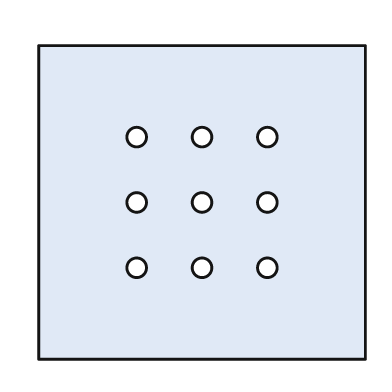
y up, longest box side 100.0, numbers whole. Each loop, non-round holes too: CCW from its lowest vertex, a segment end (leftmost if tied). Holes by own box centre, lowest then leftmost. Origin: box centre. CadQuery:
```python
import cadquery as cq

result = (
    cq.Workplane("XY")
    .moveTo(-50.0, -48.0)
    .lineTo(50.0, -48.0)
    .lineTo(50.0, 48.0)
    .lineTo(-50.0, 48.0)
    .close()
    .moveTo(-20.0, -20.0)
    .circle(3.0)
    .moveTo(0.0, -20.0)
    .circle(3.0)
    .moveTo(20.0, -20.0)
    .circle(3.0)
    .moveTo(-20.0, 0.0)
    .circle(3.0)
    .moveTo(0.0, 0.0)
    .circle(3.0)
    .moveTo(20.0, 0.0)
    .circle(3.0)
    .moveTo(-20.0, 20.0)
    .circle(3.0)
    .moveTo(0.0, 20.0)
    .circle(3.0)
    .moveTo(20.0, 20.0)
    .circle(3.0)
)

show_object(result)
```